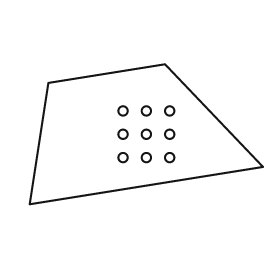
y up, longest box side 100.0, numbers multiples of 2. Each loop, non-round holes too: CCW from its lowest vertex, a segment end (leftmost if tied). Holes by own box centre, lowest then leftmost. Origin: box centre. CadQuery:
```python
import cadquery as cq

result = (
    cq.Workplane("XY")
    .moveTo(-50.0, -30.0)
    .lineTo(50.0, -14.0)
    .lineTo(8.0, 30.0)
    .lineTo(-42.0, 22.0)
    .close()
    .moveTo(-10.0, -10.0)
    .circle(2.0)
    .moveTo(0.0, -10.0)
    .circle(2.0)
    .moveTo(10.0, -10.0)
    .circle(2.0)
    .moveTo(-10.0, 0.0)
    .circle(2.0)
    .moveTo(0.0, 0.0)
    .circle(2.0)
    .moveTo(10.0, 0.0)
    .circle(2.0)
    .moveTo(-10.0, 10.0)
    .circle(2.0)
    .moveTo(0.0, 10.0)
    .circle(2.0)
    .moveTo(10.0, 10.0)
    .circle(2.0)
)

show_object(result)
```